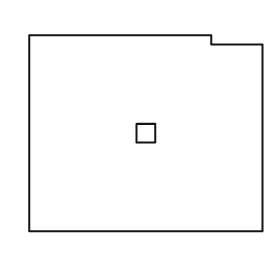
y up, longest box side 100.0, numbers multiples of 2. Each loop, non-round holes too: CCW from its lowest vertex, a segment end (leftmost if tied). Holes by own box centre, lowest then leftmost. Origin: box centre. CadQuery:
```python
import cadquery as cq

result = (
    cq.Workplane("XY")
    .moveTo(-50.0, -42.0)
    .lineTo(50.0, -42.0)
    .lineTo(50.0, 38.0)
    .lineTo(28.0, 38.0)
    .lineTo(28.0, 42.0)
    .lineTo(-50.0, 42.0)
    .close()
    .moveTo(-4.0, -4.0)
    .lineTo(4.0, -4.0)
    .lineTo(4.0, 4.0)
    .lineTo(-4.0, 4.0)
    .close()
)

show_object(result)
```